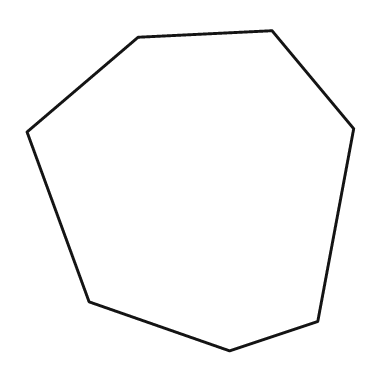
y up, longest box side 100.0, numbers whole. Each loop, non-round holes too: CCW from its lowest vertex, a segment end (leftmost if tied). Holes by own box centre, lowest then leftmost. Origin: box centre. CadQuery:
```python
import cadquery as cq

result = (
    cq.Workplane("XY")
    .moveTo(12.0, -49.0)
    .lineTo(39.0, -40.0)
    .lineTo(50.0, 19.0)
    .lineTo(25.0, 49.0)
    .lineTo(-16.0, 47.0)
    .lineTo(-50.0, 18.0)
    .lineTo(-31.0, -34.0)
    .close()
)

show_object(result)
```